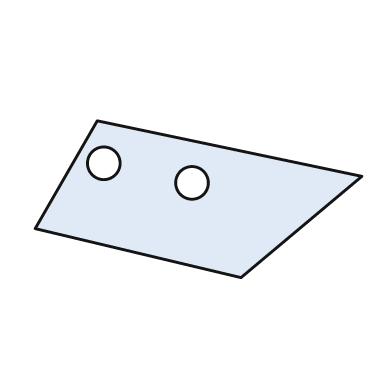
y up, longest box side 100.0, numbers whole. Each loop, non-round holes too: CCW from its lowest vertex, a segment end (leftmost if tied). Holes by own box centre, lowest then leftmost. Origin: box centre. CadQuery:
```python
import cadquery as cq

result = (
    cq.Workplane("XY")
    .moveTo(13.0, -24.0)
    .lineTo(50.0, 7.0)
    .lineTo(-31.0, 24.0)
    .lineTo(-50.0, -9.0)
    .close()
    .moveTo(-2.0, 5.0)
    .circle(5.0)
    .moveTo(-29.0, 11.0)
    .circle(5.0)
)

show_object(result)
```